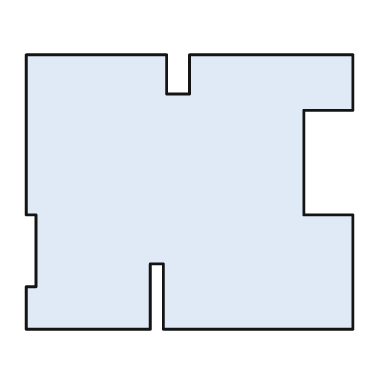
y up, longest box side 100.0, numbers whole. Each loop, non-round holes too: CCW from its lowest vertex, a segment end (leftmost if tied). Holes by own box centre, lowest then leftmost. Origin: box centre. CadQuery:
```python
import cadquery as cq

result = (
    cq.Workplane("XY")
    .moveTo(-50.0, -42.0)
    .lineTo(-12.0, -42.0)
    .lineTo(-12.0, -22.0)
    .lineTo(-8.0, -22.0)
    .lineTo(-8.0, -42.0)
    .lineTo(50.0, -42.0)
    .lineTo(50.0, -7.0)
    .lineTo(35.0, -7.0)
    .lineTo(35.0, 25.0)
    .lineTo(50.0, 25.0)
    .lineTo(50.0, 42.0)
    .lineTo(0.0, 42.0)
    .lineTo(0.0, 30.0)
    .lineTo(-7.0, 30.0)
    .lineTo(-7.0, 42.0)
    .lineTo(-50.0, 42.0)
    .lineTo(-50.0, -7.0)
    .lineTo(-47.0, -7.0)
    .lineTo(-47.0, -29.0)
    .lineTo(-50.0, -29.0)
    .close()
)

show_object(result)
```